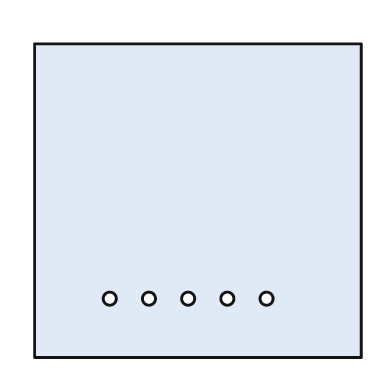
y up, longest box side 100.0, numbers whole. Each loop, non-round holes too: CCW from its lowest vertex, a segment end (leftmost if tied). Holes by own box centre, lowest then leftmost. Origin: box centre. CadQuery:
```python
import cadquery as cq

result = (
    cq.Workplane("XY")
    .moveTo(-50.0, -48.0)
    .lineTo(50.0, -48.0)
    .lineTo(50.0, 48.0)
    .lineTo(-50.0, 48.0)
    .close()
    .moveTo(-27.0, -30.0)
    .circle(2.0)
    .moveTo(-15.0, -30.0)
    .circle(2.0)
    .moveTo(-3.0, -30.0)
    .circle(2.0)
    .moveTo(9.0, -30.0)
    .circle(2.0)
    .moveTo(21.0, -30.0)
    .circle(2.0)
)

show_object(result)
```